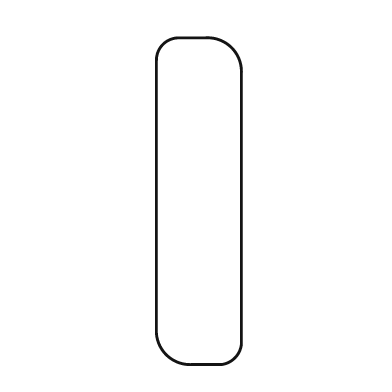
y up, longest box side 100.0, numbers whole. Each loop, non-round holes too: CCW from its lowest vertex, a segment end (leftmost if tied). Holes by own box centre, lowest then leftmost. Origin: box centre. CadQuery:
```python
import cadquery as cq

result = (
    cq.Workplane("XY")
    .moveTo(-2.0, -50.0)
    .lineTo(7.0, -50.0)
    .threePointArc((11.0, -48.0), (13.0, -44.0))
    .lineTo(13.0, 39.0)
    .threePointArc((10.0, 47.0), (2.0, 50.0))
    .lineTo(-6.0, 50.0)
    .threePointArc((-11.0, 48.0), (-13.0, 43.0))
    .lineTo(-13.0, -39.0)
    .threePointArc((-10.0, -47.0), (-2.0, -50.0))
    .close()
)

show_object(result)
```